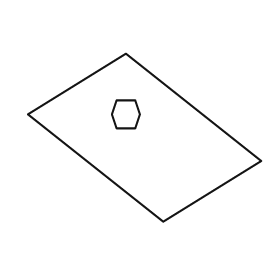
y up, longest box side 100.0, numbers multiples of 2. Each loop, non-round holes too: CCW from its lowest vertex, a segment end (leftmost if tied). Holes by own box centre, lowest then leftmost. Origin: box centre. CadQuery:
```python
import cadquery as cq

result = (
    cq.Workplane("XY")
    .moveTo(8.0, -36.0)
    .lineTo(50.0, -10.0)
    .lineTo(-8.0, 36.0)
    .lineTo(-50.0, 10.0)
    .close()
    .moveTo(-12.0, 4.0)
    .lineTo(-4.0, 4.0)
    .lineTo(-2.0, 10.0)
    .lineTo(-4.0, 16.0)
    .lineTo(-12.0, 16.0)
    .lineTo(-14.0, 10.0)
    .close()
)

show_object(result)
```